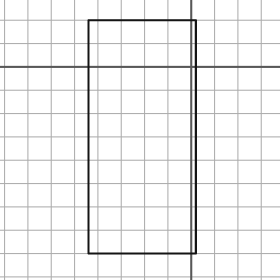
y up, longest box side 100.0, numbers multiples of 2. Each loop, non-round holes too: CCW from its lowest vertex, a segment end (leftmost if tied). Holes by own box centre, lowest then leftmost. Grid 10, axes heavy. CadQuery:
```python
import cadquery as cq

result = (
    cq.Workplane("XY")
    .moveTo(-44.0, -80.0)
    .lineTo(2.0, -80.0)
    .lineTo(2.0, 20.0)
    .lineTo(-44.0, 20.0)
    .close()
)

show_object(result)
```